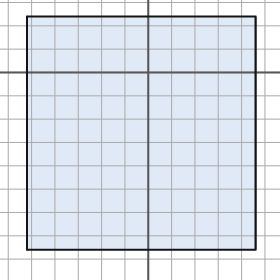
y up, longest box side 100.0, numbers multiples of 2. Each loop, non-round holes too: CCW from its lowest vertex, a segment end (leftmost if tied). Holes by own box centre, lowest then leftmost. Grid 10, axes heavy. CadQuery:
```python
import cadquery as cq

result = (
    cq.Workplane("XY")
    .moveTo(-52.0, -76.0)
    .lineTo(46.0, -76.0)
    .lineTo(46.0, 24.0)
    .lineTo(-52.0, 24.0)
    .close()
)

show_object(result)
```